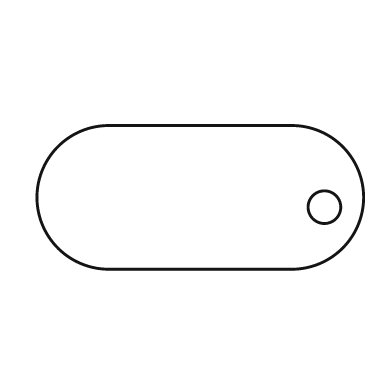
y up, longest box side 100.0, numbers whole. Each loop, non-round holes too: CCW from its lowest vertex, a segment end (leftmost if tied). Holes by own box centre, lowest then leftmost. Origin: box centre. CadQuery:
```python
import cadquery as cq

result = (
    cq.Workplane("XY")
    .moveTo(-28.0, -22.0)
    .lineTo(28.0, -22.0)
    .threePointArc((50.0, 0.0), (28.0, 22.0))
    .lineTo(-28.0, 22.0)
    .threePointArc((-50.0, 0.0), (-28.0, -22.0))
    .close()
    .moveTo(38.0, -3.0)
    .circle(5.0)
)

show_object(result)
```